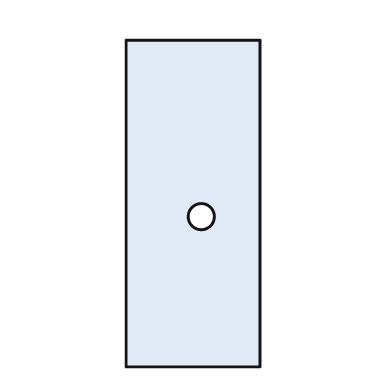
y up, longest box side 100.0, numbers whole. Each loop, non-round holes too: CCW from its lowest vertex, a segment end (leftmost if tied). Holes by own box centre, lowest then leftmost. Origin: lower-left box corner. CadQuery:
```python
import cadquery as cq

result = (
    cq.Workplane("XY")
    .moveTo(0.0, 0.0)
    .lineTo(41.0, 0.0)
    .lineTo(41.0, 100.0)
    .lineTo(0.0, 100.0)
    .close()
    .moveTo(23.0, 46.0)
    .circle(4.0)
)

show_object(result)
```